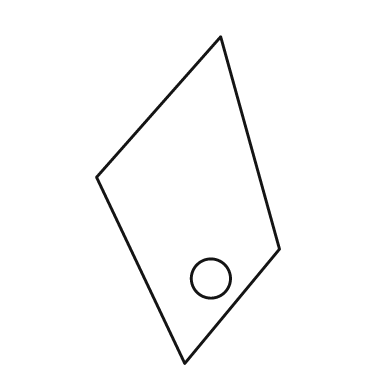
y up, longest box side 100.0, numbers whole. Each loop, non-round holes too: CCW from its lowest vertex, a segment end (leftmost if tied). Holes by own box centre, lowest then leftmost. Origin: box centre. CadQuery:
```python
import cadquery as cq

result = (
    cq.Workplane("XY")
    .moveTo(-1.0, -50.0)
    .lineTo(28.0, -15.0)
    .lineTo(10.0, 50.0)
    .lineTo(-28.0, 7.0)
    .close()
    .moveTo(7.0, -24.0)
    .circle(6.0)
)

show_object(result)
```